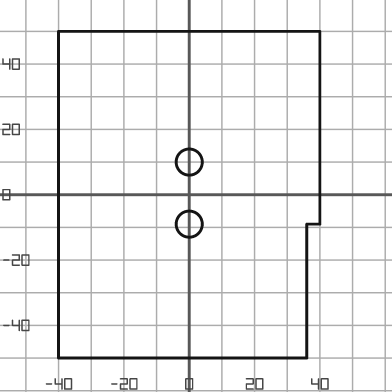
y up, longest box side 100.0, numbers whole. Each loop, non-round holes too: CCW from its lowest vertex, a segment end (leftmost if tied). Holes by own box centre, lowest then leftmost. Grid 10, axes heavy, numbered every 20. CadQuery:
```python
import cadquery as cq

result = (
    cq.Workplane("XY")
    .moveTo(-40.0, -50.0)
    .lineTo(36.0, -50.0)
    .lineTo(36.0, -9.0)
    .lineTo(40.0, -9.0)
    .lineTo(40.0, 50.0)
    .lineTo(-40.0, 50.0)
    .close()
    .moveTo(0.0, -9.0)
    .circle(4.0)
    .moveTo(0.0, 10.0)
    .circle(4.0)
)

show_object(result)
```